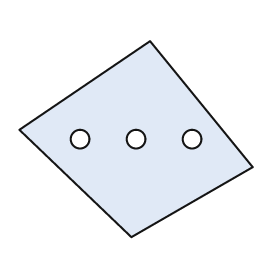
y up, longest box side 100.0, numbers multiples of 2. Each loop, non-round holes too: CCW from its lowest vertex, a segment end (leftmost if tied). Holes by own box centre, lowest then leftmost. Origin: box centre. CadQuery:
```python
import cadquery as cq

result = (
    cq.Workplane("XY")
    .moveTo(-2.0, -42.0)
    .lineTo(50.0, -12.0)
    .lineTo(6.0, 42.0)
    .lineTo(-50.0, 4.0)
    .close()
    .moveTo(-24.0, 0.0)
    .circle(4.0)
    .moveTo(0.0, 0.0)
    .circle(4.0)
    .moveTo(24.0, 0.0)
    .circle(4.0)
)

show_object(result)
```